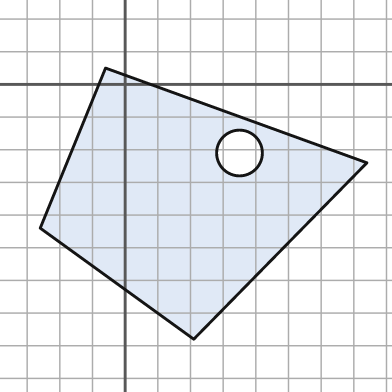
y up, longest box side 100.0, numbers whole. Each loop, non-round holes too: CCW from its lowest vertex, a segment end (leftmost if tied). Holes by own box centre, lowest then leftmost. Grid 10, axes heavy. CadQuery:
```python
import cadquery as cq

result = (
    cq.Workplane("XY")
    .moveTo(21.0, -78.0)
    .lineTo(74.0, -24.0)
    .lineTo(-6.0, 5.0)
    .lineTo(-26.0, -44.0)
    .close()
    .moveTo(35.0, -21.0)
    .circle(7.0)
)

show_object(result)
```